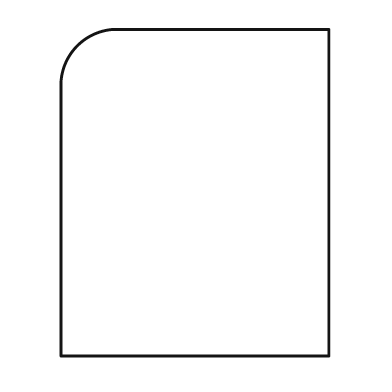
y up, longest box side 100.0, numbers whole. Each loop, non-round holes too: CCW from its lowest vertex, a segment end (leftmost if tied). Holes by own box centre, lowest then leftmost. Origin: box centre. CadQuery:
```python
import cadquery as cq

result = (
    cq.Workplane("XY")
    .moveTo(-41.0, -50.0)
    .lineTo(41.0, -50.0)
    .lineTo(41.0, 50.0)
    .lineTo(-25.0, 50.0)
    .threePointArc((-36.0, 45.0), (-41.0, 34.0))
    .close()
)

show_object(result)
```